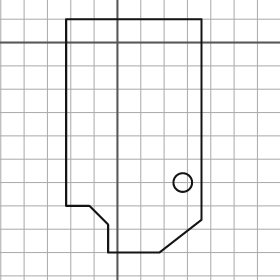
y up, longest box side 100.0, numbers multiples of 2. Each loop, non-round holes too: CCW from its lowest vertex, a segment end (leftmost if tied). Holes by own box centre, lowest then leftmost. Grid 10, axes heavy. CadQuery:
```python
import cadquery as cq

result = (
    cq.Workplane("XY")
    .moveTo(-4.0, -90.0)
    .lineTo(18.0, -90.0)
    .lineTo(36.0, -76.0)
    .lineTo(36.0, 10.0)
    .lineTo(-22.0, 10.0)
    .lineTo(-22.0, -70.0)
    .lineTo(-12.0, -70.0)
    .lineTo(-4.0, -78.0)
    .close()
    .moveTo(28.0, -60.0)
    .circle(4.0)
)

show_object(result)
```